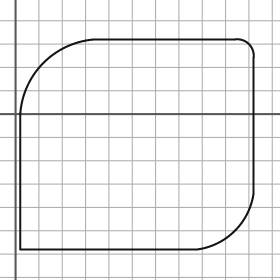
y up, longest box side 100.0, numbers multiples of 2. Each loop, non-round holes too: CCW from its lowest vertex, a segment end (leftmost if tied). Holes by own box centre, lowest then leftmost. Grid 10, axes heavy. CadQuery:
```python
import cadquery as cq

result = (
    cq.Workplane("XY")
    .moveTo(2.0, -58.0)
    .lineTo(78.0, -58.0)
    .threePointArc((94.0, -50.0), (102.0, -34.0))
    .lineTo(102.0, 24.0)
    .threePointArc((100.0, 30.0), (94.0, 32.0))
    .lineTo(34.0, 32.0)
    .threePointArc((12.0, 22.0), (2.0, 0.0))
    .close()
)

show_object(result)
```